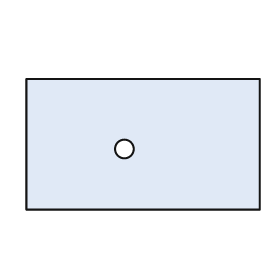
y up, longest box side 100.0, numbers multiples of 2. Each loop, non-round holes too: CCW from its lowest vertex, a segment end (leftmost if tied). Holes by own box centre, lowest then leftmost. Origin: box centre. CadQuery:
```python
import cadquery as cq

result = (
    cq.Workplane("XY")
    .moveTo(-50.0, -28.0)
    .lineTo(50.0, -28.0)
    .lineTo(50.0, 28.0)
    .lineTo(-50.0, 28.0)
    .close()
    .moveTo(-8.0, -2.0)
    .circle(4.0)
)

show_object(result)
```